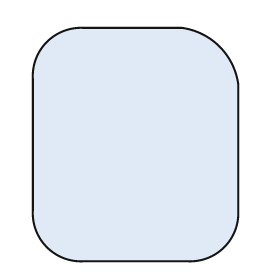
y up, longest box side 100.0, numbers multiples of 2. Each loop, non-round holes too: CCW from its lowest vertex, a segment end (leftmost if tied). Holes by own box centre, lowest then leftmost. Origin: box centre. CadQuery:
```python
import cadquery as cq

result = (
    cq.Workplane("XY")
    .moveTo(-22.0, -50.0)
    .lineTo(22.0, -50.0)
    .threePointArc((38.0, -44.0), (44.0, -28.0))
    .lineTo(44.0, 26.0)
    .threePointArc((36.0, 42.0), (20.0, 50.0))
    .lineTo(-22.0, 50.0)
    .threePointArc((-38.0, 44.0), (-44.0, 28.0))
    .lineTo(-44.0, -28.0)
    .threePointArc((-38.0, -44.0), (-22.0, -50.0))
    .close()
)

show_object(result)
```